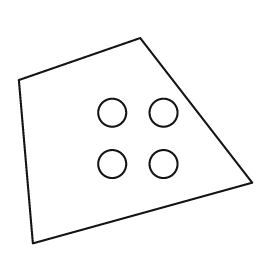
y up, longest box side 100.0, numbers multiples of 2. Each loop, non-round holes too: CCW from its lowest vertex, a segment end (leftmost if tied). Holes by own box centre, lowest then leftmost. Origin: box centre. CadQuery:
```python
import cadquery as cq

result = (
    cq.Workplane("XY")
    .moveTo(-44.0, -44.0)
    .lineTo(50.0, -18.0)
    .lineTo(2.0, 44.0)
    .lineTo(-50.0, 26.0)
    .close()
    .moveTo(-10.0, -10.0)
    .circle(6.0)
    .moveTo(12.0, -10.0)
    .circle(6.0)
    .moveTo(-10.0, 12.0)
    .circle(6.0)
    .moveTo(12.0, 12.0)
    .circle(6.0)
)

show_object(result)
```